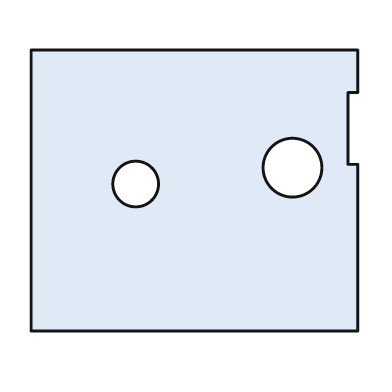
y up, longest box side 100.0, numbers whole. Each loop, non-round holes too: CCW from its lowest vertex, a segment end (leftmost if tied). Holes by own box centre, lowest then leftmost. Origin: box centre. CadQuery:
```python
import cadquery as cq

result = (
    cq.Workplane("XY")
    .moveTo(-50.0, -43.0)
    .lineTo(50.0, -43.0)
    .lineTo(50.0, 8.0)
    .lineTo(47.0, 8.0)
    .lineTo(47.0, 30.0)
    .lineTo(50.0, 30.0)
    .lineTo(50.0, 43.0)
    .lineTo(-50.0, 43.0)
    .close()
    .moveTo(-18.0, 2.0)
    .circle(7.0)
    .moveTo(30.0, 7.0)
    .circle(9.0)
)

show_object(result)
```